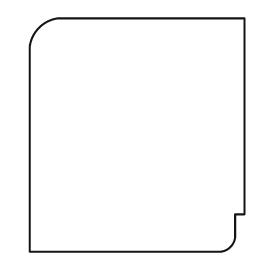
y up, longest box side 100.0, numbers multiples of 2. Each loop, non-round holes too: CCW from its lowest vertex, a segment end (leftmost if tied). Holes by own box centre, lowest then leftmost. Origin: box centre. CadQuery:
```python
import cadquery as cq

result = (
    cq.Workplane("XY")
    .moveTo(-46.0, -50.0)
    .lineTo(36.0, -50.0)
    .threePointArc((40.0, -48.0), (42.0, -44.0))
    .lineTo(42.0, -34.0)
    .lineTo(46.0, -34.0)
    .lineTo(46.0, 50.0)
    .lineTo(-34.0, 50.0)
    .threePointArc((-42.0, 46.0), (-46.0, 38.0))
    .close()
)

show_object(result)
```